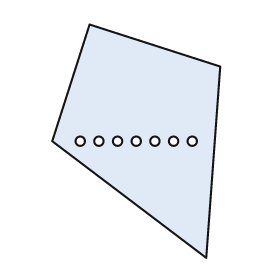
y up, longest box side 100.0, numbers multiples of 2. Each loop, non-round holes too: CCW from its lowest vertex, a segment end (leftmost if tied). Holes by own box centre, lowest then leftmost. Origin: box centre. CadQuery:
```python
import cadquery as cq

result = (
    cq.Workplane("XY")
    .moveTo(30.0, -50.0)
    .lineTo(36.0, 32.0)
    .lineTo(-20.0, 50.0)
    .lineTo(-36.0, 0.0)
    .close()
    .moveTo(-24.0, 0.0)
    .circle(2.0)
    .moveTo(-16.0, 0.0)
    .circle(2.0)
    .moveTo(-8.0, 0.0)
    .circle(2.0)
    .moveTo(0.0, 0.0)
    .circle(2.0)
    .moveTo(8.0, 0.0)
    .circle(2.0)
    .moveTo(16.0, 0.0)
    .circle(2.0)
    .moveTo(24.0, 0.0)
    .circle(2.0)
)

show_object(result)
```